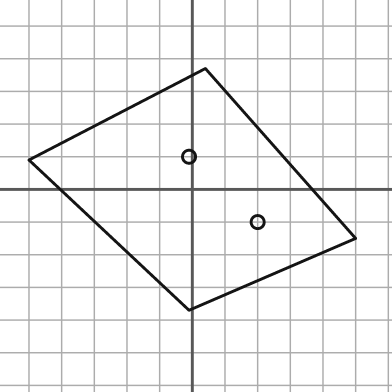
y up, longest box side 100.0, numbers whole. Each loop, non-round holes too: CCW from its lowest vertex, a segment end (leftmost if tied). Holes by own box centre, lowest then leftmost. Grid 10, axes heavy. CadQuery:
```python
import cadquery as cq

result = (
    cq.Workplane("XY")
    .moveTo(-1.0, -37.0)
    .lineTo(50.0, -15.0)
    .lineTo(4.0, 37.0)
    .lineTo(-50.0, 9.0)
    .close()
    .moveTo(20.0, -10.0)
    .circle(2.0)
    .moveTo(-1.0, 10.0)
    .circle(2.0)
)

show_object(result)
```